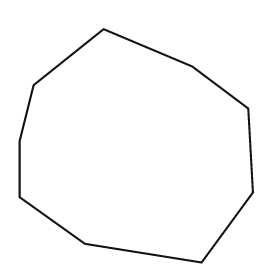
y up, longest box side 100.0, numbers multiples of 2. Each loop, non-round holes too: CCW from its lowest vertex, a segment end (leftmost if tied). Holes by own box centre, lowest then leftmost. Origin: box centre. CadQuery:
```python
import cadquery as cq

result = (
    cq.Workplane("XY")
    .moveTo(28.0, -50.0)
    .lineTo(50.0, -20.0)
    .lineTo(48.0, 16.0)
    .lineTo(24.0, 34.0)
    .lineTo(-14.0, 50.0)
    .lineTo(-44.0, 26.0)
    .lineTo(-50.0, 2.0)
    .lineTo(-50.0, -22.0)
    .lineTo(-22.0, -42.0)
    .close()
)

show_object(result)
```